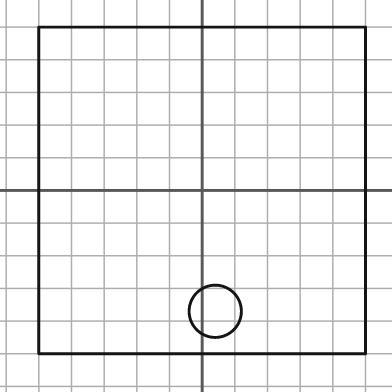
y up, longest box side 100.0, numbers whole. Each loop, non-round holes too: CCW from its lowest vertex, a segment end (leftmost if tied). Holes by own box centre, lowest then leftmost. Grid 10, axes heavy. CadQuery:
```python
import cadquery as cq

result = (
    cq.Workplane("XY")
    .moveTo(-50.0, -50.0)
    .lineTo(50.0, -50.0)
    .lineTo(50.0, 50.0)
    .lineTo(-50.0, 50.0)
    .close()
    .moveTo(4.0, -37.0)
    .circle(8.0)
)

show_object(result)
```